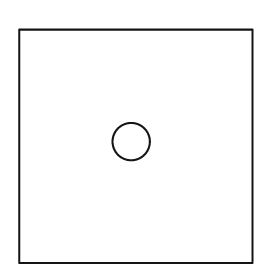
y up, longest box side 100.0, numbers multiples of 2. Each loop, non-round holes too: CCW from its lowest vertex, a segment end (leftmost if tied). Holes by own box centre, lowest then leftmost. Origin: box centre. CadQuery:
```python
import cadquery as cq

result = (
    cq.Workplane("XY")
    .moveTo(-50.0, -50.0)
    .lineTo(50.0, -50.0)
    .lineTo(50.0, 50.0)
    .lineTo(-50.0, 50.0)
    .close()
    .moveTo(-2.0, 2.0)
    .circle(8.0)
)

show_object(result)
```